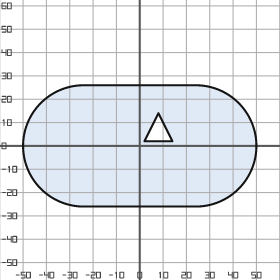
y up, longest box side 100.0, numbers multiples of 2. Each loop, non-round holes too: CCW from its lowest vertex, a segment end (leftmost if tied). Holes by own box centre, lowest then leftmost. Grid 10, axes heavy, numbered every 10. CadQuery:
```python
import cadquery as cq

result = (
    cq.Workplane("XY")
    .moveTo(-24.0, -26.0)
    .lineTo(24.0, -26.0)
    .threePointArc((50.0, 0.0), (24.0, 26.0))
    .lineTo(-24.0, 26.0)
    .threePointArc((-50.0, 0.0), (-24.0, -26.0))
    .close()
    .moveTo(2.0, 2.0)
    .lineTo(14.0, 2.0)
    .lineTo(8.0, 14.0)
    .close()
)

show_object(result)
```